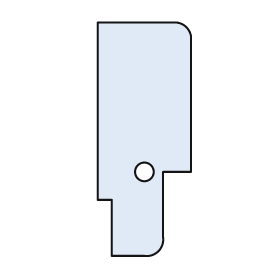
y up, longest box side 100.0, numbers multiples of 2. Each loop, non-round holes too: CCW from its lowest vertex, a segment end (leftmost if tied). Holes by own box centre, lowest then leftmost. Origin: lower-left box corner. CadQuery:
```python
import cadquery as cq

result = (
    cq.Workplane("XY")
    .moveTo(6.0, 0.0)
    .lineTo(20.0, 0.0)
    .threePointArc((26.0, 2.0), (28.0, 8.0))
    .lineTo(28.0, 36.0)
    .lineTo(40.0, 36.0)
    .lineTo(40.0, 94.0)
    .threePointArc((38.0, 98.0), (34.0, 100.0))
    .lineTo(0.0, 100.0)
    .lineTo(0.0, 24.0)
    .lineTo(6.0, 24.0)
    .close()
    .moveTo(20.0, 36.0)
    .circle(4.0)
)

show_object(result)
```